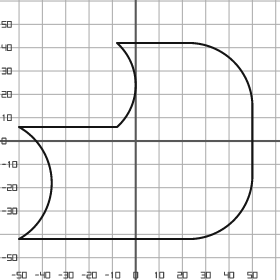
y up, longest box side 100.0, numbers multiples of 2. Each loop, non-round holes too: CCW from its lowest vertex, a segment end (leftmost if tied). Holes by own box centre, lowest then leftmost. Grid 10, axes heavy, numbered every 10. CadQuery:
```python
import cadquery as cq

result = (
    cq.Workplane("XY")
    .moveTo(-50.0, -42.0)
    .lineTo(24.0, -42.0)
    .threePointArc((42.0, -34.0), (50.0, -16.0))
    .lineTo(50.0, 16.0)
    .threePointArc((42.0, 34.0), (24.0, 42.0))
    .lineTo(-8.0, 42.0)
    .threePointArc((0.0, 24.0), (-8.0, 6.0))
    .lineTo(-50.0, 6.0)
    .threePointArc((-36.0, -18.0), (-50.0, -42.0))
    .close()
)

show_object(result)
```